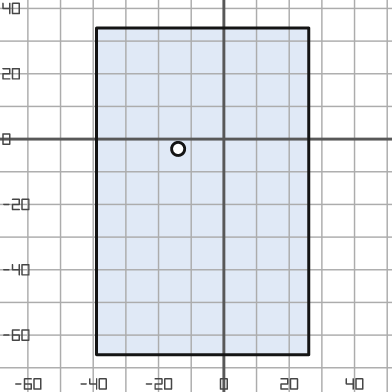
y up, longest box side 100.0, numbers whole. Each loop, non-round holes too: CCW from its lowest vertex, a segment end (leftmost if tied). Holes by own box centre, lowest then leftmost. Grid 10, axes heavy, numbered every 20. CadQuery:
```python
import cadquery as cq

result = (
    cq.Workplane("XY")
    .moveTo(-39.0, -66.0)
    .lineTo(26.0, -66.0)
    .lineTo(26.0, 34.0)
    .lineTo(-39.0, 34.0)
    .close()
    .moveTo(-14.0, -3.0)
    .circle(2.0)
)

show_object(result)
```